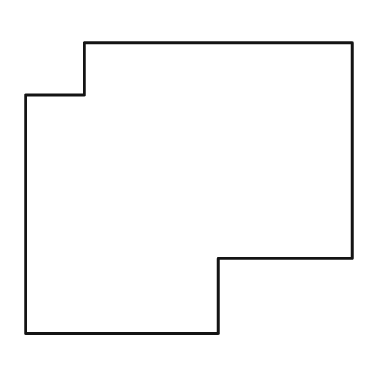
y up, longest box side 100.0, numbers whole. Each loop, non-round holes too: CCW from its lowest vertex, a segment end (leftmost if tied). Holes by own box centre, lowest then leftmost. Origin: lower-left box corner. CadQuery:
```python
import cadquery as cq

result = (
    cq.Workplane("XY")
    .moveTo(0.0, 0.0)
    .lineTo(59.0, 0.0)
    .lineTo(59.0, 23.0)
    .lineTo(100.0, 23.0)
    .lineTo(100.0, 89.0)
    .lineTo(18.0, 89.0)
    .lineTo(18.0, 73.0)
    .lineTo(0.0, 73.0)
    .close()
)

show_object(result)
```